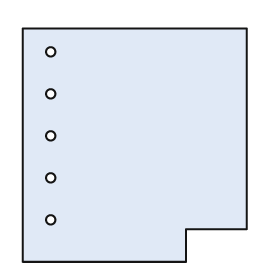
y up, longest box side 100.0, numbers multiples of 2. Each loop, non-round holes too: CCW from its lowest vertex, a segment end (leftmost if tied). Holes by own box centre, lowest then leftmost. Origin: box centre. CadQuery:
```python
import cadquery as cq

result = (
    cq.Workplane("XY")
    .moveTo(-48.0, -50.0)
    .lineTo(22.0, -50.0)
    .lineTo(22.0, -36.0)
    .lineTo(48.0, -36.0)
    .lineTo(48.0, 50.0)
    .lineTo(-48.0, 50.0)
    .close()
    .moveTo(-36.0, -32.0)
    .circle(2.0)
    .moveTo(-36.0, -14.0)
    .circle(2.0)
    .moveTo(-36.0, 4.0)
    .circle(2.0)
    .moveTo(-36.0, 22.0)
    .circle(2.0)
    .moveTo(-36.0, 40.0)
    .circle(2.0)
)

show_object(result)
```